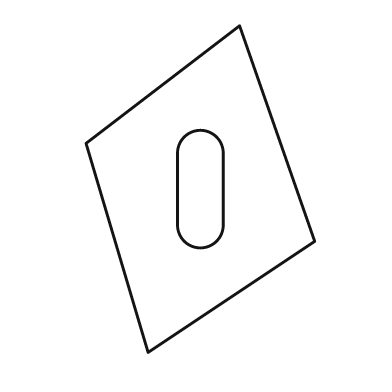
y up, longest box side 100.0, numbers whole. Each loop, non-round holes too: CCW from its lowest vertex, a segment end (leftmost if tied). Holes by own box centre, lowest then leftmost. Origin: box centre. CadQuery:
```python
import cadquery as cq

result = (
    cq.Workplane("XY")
    .moveTo(-16.0, -50.0)
    .lineTo(35.0, -16.0)
    .lineTo(12.0, 50.0)
    .lineTo(-35.0, 14.0)
    .close()
    .moveTo(-7.0, -11.0)
    .threePointArc((0.0, -18.0), (7.0, -11.0))
    .lineTo(7.0, 11.0)
    .threePointArc((0.0, 18.0), (-7.0, 11.0))
    .close()
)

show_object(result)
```